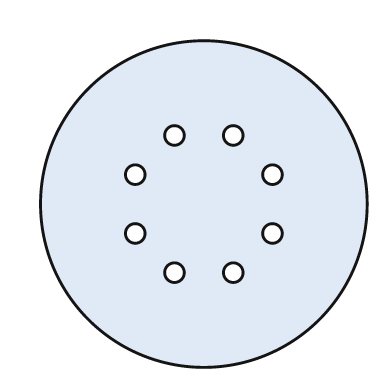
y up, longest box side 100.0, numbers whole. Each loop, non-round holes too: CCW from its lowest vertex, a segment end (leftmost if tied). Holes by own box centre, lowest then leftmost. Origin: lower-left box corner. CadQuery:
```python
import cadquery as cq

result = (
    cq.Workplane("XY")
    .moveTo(50.0, 50.0)
    .circle(50.0)
    .moveTo(41.0, 29.0)
    .circle(3.0)
    .moveTo(59.0, 29.0)
    .circle(3.0)
    .moveTo(29.0, 41.0)
    .circle(3.0)
    .moveTo(71.0, 41.0)
    .circle(3.0)
    .moveTo(29.0, 59.0)
    .circle(3.0)
    .moveTo(71.0, 59.0)
    .circle(3.0)
    .moveTo(41.0, 71.0)
    .circle(3.0)
    .moveTo(59.0, 71.0)
    .circle(3.0)
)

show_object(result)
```